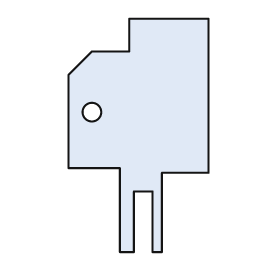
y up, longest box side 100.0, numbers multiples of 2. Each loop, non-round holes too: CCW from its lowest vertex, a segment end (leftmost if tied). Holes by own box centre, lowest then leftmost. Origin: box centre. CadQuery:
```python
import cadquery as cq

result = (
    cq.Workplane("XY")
    .moveTo(-8.0, -50.0)
    .lineTo(-2.0, -50.0)
    .lineTo(-2.0, -24.0)
    .lineTo(6.0, -24.0)
    .lineTo(6.0, -50.0)
    .lineTo(10.0, -50.0)
    .lineTo(10.0, -16.0)
    .lineTo(30.0, -16.0)
    .lineTo(30.0, 50.0)
    .lineTo(-4.0, 50.0)
    .lineTo(-4.0, 36.0)
    .lineTo(-20.0, 36.0)
    .lineTo(-30.0, 26.0)
    .lineTo(-30.0, -14.0)
    .lineTo(-8.0, -14.0)
    .close()
    .moveTo(-20.0, 10.0)
    .circle(4.0)
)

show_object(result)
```